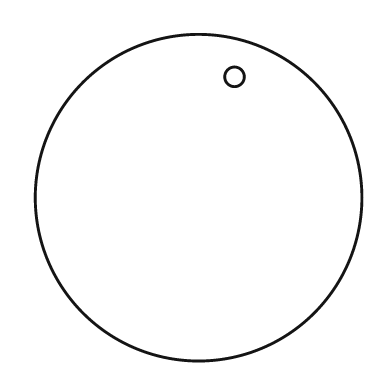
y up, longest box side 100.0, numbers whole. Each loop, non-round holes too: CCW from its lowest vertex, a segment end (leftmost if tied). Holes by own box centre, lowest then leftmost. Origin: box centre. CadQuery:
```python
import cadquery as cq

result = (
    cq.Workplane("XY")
    .moveTo(0.0, 0.0)
    .circle(50.0)
    .moveTo(11.0, 37.0)
    .circle(3.0)
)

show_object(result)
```